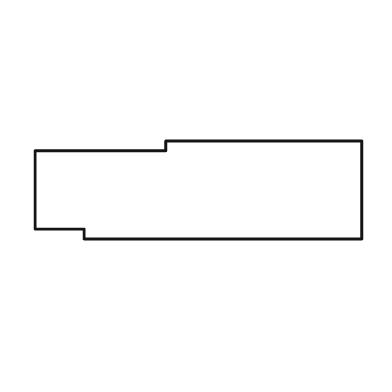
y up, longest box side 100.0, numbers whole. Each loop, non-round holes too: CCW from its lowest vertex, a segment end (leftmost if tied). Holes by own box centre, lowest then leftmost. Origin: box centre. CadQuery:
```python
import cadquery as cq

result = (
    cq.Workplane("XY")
    .moveTo(-35.0, -15.0)
    .lineTo(50.0, -15.0)
    .lineTo(50.0, 15.0)
    .lineTo(-10.0, 15.0)
    .lineTo(-10.0, 12.0)
    .lineTo(-50.0, 12.0)
    .lineTo(-50.0, -12.0)
    .lineTo(-35.0, -12.0)
    .close()
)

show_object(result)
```